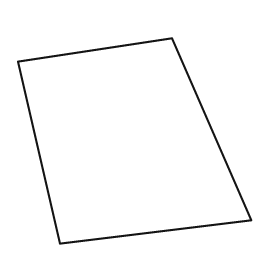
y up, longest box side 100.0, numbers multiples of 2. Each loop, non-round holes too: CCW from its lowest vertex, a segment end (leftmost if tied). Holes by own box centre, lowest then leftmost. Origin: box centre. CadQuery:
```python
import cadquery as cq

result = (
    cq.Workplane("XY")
    .moveTo(-32.0, -44.0)
    .lineTo(50.0, -34.0)
    .lineTo(16.0, 44.0)
    .lineTo(-50.0, 34.0)
    .close()
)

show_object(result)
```